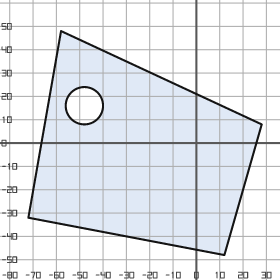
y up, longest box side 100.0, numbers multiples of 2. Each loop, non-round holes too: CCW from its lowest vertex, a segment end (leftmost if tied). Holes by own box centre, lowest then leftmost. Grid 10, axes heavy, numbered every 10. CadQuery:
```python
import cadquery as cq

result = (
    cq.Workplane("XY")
    .moveTo(12.0, -48.0)
    .lineTo(28.0, 8.0)
    .lineTo(-58.0, 48.0)
    .lineTo(-72.0, -32.0)
    .close()
    .moveTo(-48.0, 16.0)
    .circle(8.0)
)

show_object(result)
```